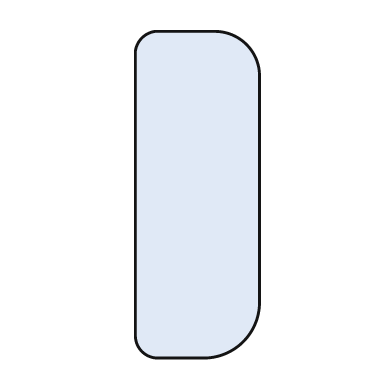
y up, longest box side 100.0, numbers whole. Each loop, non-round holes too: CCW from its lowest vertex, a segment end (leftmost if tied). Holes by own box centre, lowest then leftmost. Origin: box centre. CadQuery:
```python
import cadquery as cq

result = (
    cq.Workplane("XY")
    .moveTo(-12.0, -50.0)
    .lineTo(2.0, -50.0)
    .threePointArc((14.0, -45.0), (19.0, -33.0))
    .lineTo(19.0, 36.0)
    .threePointArc((15.0, 46.0), (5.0, 50.0))
    .lineTo(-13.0, 50.0)
    .threePointArc((-17.0, 48.0), (-19.0, 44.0))
    .lineTo(-19.0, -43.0)
    .threePointArc((-17.0, -48.0), (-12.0, -50.0))
    .close()
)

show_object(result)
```